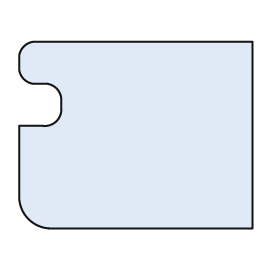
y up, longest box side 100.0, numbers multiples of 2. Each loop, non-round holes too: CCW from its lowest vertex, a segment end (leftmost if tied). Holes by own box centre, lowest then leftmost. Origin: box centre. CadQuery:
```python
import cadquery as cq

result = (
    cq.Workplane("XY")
    .moveTo(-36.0, -40.0)
    .lineTo(50.0, -40.0)
    .lineTo(50.0, 40.0)
    .lineTo(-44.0, 40.0)
    .threePointArc((-48.0, 38.0), (-50.0, 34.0))
    .lineTo(-50.0, 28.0)
    .threePointArc((-48.0, 24.0), (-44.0, 22.0))
    .lineTo(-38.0, 22.0)
    .threePointArc((-34.0, 20.0), (-32.0, 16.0))
    .lineTo(-32.0, 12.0)
    .threePointArc((-34.0, 6.0), (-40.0, 4.0))
    .lineTo(-50.0, 4.0)
    .lineTo(-50.0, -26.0)
    .threePointArc((-46.0, -36.0), (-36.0, -40.0))
    .close()
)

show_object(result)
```